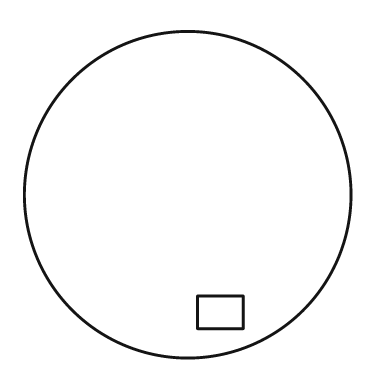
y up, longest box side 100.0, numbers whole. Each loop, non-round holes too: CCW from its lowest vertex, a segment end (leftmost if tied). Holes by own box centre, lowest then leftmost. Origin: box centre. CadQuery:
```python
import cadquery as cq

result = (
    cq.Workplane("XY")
    .moveTo(0.0, 0.0)
    .circle(50.0)
    .moveTo(3.0, -41.0)
    .lineTo(17.0, -41.0)
    .lineTo(17.0, -31.0)
    .lineTo(3.0, -31.0)
    .close()
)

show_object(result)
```